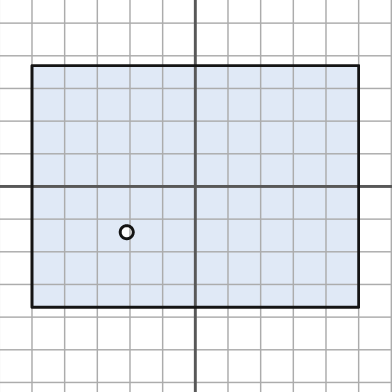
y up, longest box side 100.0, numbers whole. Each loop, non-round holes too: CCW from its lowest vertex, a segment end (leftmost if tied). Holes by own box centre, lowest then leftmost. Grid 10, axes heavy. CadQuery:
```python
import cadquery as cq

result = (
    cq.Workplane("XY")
    .moveTo(-50.0, -37.0)
    .lineTo(50.0, -37.0)
    .lineTo(50.0, 37.0)
    .lineTo(-50.0, 37.0)
    .close()
    .moveTo(-21.0, -14.0)
    .circle(2.0)
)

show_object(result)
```